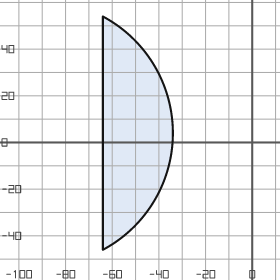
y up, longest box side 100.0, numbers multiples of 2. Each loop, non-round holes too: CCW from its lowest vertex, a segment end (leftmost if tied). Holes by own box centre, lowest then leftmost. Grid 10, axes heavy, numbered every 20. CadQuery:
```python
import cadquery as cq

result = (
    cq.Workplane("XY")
    .moveTo(-64.0, -46.0)
    .threePointArc((-34.0, 4.0), (-64.0, 54.0))
    .close()
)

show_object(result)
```